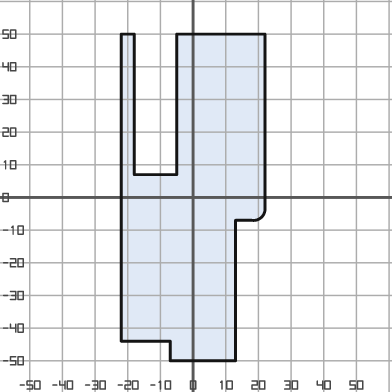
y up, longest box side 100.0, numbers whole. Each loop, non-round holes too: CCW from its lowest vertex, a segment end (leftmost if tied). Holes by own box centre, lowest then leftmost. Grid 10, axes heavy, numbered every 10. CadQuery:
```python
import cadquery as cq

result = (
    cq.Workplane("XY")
    .moveTo(-7.0, -50.0)
    .lineTo(13.0, -50.0)
    .lineTo(13.0, -7.0)
    .lineTo(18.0, -7.0)
    .threePointArc((21.0, -6.0), (22.0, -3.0))
    .lineTo(22.0, 50.0)
    .lineTo(-5.0, 50.0)
    .lineTo(-5.0, 7.0)
    .lineTo(-18.0, 7.0)
    .lineTo(-18.0, 50.0)
    .lineTo(-22.0, 50.0)
    .lineTo(-22.0, -44.0)
    .lineTo(-7.0, -44.0)
    .close()
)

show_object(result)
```